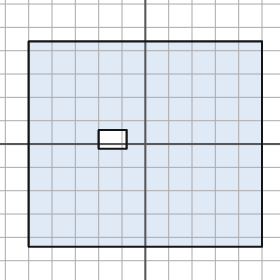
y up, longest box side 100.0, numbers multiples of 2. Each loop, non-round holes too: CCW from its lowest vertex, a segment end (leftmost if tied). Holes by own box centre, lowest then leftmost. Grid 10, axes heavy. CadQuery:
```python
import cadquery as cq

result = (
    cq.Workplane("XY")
    .moveTo(-50.0, -44.0)
    .lineTo(50.0, -44.0)
    .lineTo(50.0, 44.0)
    .lineTo(-50.0, 44.0)
    .close()
    .moveTo(-20.0, -2.0)
    .lineTo(-8.0, -2.0)
    .lineTo(-8.0, 6.0)
    .lineTo(-20.0, 6.0)
    .close()
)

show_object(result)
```